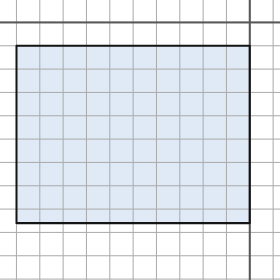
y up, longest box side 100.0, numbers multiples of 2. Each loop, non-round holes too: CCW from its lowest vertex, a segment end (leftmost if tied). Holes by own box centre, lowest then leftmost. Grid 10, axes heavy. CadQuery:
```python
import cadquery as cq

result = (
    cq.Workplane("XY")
    .moveTo(-100.0, -86.0)
    .lineTo(0.0, -86.0)
    .lineTo(0.0, -10.0)
    .lineTo(-100.0, -10.0)
    .close()
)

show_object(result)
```